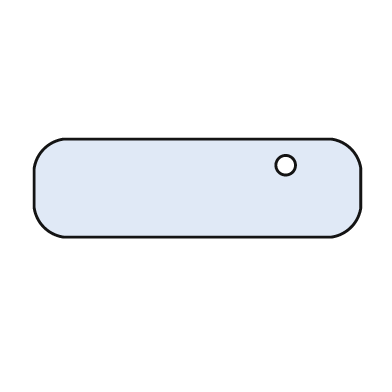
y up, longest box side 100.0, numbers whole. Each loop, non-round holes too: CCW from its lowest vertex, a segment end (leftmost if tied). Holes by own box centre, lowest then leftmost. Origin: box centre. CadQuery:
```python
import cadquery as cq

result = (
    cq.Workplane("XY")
    .moveTo(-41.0, -15.0)
    .lineTo(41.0, -15.0)
    .threePointArc((47.0, -12.0), (50.0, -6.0))
    .lineTo(50.0, 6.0)
    .threePointArc((47.0, 12.0), (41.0, 15.0))
    .lineTo(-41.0, 15.0)
    .threePointArc((-47.0, 12.0), (-50.0, 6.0))
    .lineTo(-50.0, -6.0)
    .threePointArc((-47.0, -12.0), (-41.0, -15.0))
    .close()
    .moveTo(27.0, 7.0)
    .circle(3.0)
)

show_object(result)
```